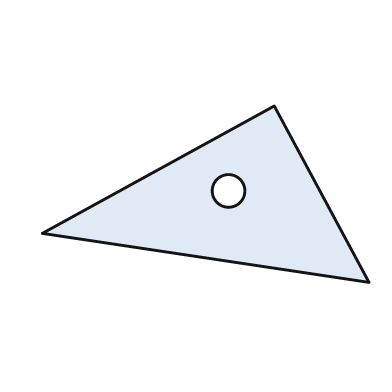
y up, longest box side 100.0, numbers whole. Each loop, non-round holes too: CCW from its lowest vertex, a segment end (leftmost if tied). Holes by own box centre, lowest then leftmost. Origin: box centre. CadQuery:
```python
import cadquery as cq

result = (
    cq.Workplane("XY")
    .moveTo(50.0, -27.0)
    .lineTo(21.0, 27.0)
    .lineTo(-50.0, -12.0)
    .close()
    .moveTo(7.0, 1.0)
    .circle(5.0)
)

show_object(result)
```